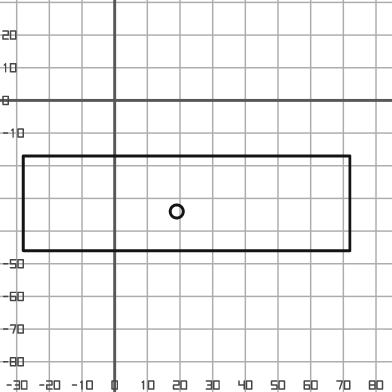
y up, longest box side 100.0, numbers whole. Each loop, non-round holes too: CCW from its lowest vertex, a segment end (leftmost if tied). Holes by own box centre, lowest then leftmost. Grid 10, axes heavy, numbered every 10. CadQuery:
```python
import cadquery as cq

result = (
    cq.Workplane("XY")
    .moveTo(-28.0, -46.0)
    .lineTo(72.0, -46.0)
    .lineTo(72.0, -17.0)
    .lineTo(-28.0, -17.0)
    .close()
    .moveTo(19.0, -34.0)
    .circle(2.0)
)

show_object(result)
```